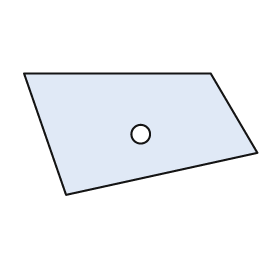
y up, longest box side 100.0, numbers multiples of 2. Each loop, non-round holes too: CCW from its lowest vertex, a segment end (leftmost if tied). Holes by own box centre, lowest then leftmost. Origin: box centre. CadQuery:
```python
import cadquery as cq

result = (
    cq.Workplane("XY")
    .moveTo(-32.0, -26.0)
    .lineTo(50.0, -8.0)
    .lineTo(30.0, 26.0)
    .lineTo(-50.0, 26.0)
    .close()
    .moveTo(0.0, 0.0)
    .circle(4.0)
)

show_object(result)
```